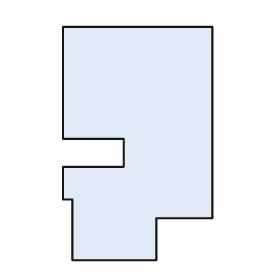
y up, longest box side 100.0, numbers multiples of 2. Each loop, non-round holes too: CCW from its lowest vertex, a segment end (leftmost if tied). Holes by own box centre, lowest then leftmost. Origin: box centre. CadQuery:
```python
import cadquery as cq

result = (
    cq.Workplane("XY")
    .moveTo(-28.0, -50.0)
    .lineTo(8.0, -50.0)
    .lineTo(8.0, -32.0)
    .lineTo(32.0, -32.0)
    .lineTo(32.0, 50.0)
    .lineTo(-32.0, 50.0)
    .lineTo(-32.0, 2.0)
    .lineTo(-6.0, 2.0)
    .lineTo(-6.0, -10.0)
    .lineTo(-32.0, -10.0)
    .lineTo(-32.0, -24.0)
    .lineTo(-28.0, -24.0)
    .close()
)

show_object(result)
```